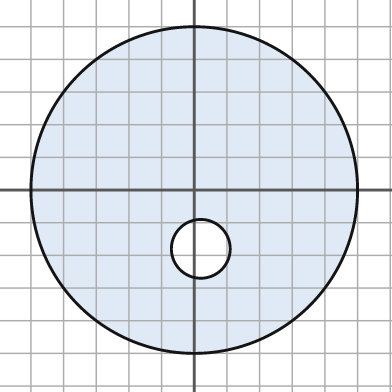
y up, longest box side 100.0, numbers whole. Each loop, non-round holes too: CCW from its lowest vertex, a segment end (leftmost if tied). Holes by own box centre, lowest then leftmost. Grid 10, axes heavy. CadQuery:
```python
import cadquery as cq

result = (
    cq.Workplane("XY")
    .moveTo(0.0, 0.0)
    .circle(50.0)
    .moveTo(2.0, -18.0)
    .circle(9.0)
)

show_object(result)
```